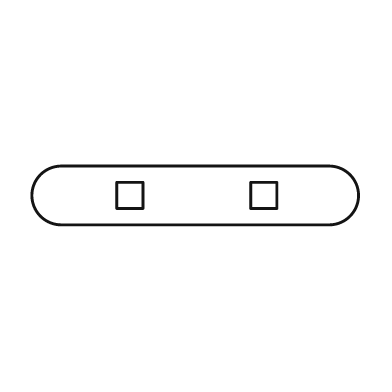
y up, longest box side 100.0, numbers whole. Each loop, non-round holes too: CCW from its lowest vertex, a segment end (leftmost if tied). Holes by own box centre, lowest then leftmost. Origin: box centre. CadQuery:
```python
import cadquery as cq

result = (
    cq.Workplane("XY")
    .moveTo(-41.0, -9.0)
    .lineTo(41.0, -9.0)
    .threePointArc((50.0, 0.0), (41.0, 9.0))
    .lineTo(-41.0, 9.0)
    .threePointArc((-50.0, 0.0), (-41.0, -9.0))
    .close()
    .moveTo(-24.0, -4.0)
    .lineTo(-16.0, -4.0)
    .lineTo(-16.0, 4.0)
    .lineTo(-24.0, 4.0)
    .close()
    .moveTo(17.0, -4.0)
    .lineTo(25.0, -4.0)
    .lineTo(25.0, 4.0)
    .lineTo(17.0, 4.0)
    .close()
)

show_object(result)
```